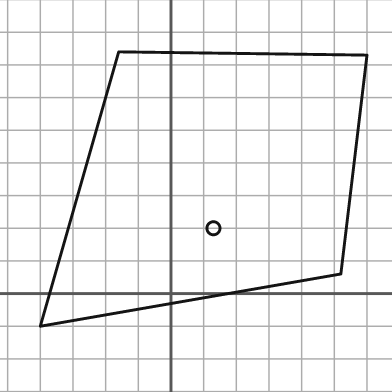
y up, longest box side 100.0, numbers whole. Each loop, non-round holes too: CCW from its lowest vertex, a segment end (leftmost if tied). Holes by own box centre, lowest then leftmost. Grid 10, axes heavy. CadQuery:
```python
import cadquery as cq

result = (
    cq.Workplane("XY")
    .moveTo(-40.0, -10.0)
    .lineTo(52.0, 6.0)
    .lineTo(60.0, 73.0)
    .lineTo(-16.0, 74.0)
    .close()
    .moveTo(13.0, 20.0)
    .circle(2.0)
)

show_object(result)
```